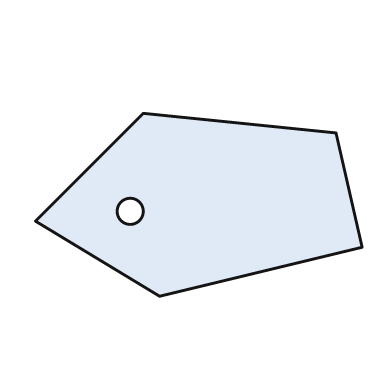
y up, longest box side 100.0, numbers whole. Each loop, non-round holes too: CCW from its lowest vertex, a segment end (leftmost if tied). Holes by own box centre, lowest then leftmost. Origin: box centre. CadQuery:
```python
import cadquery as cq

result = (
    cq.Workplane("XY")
    .moveTo(-12.0, -28.0)
    .lineTo(50.0, -13.0)
    .lineTo(42.0, 22.0)
    .lineTo(-17.0, 28.0)
    .lineTo(-50.0, -5.0)
    .close()
    .moveTo(-21.0, -2.0)
    .circle(4.0)
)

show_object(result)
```